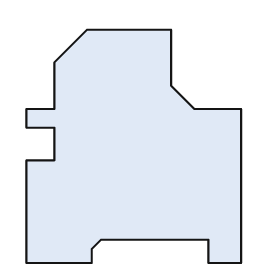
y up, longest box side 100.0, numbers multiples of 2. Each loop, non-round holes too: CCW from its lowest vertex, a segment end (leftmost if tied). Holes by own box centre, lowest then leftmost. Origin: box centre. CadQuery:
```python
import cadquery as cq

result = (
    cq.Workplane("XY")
    .moveTo(-46.0, -50.0)
    .lineTo(-18.0, -50.0)
    .lineTo(-18.0, -44.0)
    .lineTo(-14.0, -40.0)
    .lineTo(32.0, -40.0)
    .lineTo(32.0, -50.0)
    .lineTo(46.0, -50.0)
    .lineTo(46.0, 16.0)
    .lineTo(26.0, 16.0)
    .lineTo(16.0, 26.0)
    .lineTo(16.0, 50.0)
    .lineTo(-20.0, 50.0)
    .lineTo(-34.0, 36.0)
    .lineTo(-34.0, 16.0)
    .lineTo(-46.0, 16.0)
    .lineTo(-46.0, 8.0)
    .lineTo(-34.0, 8.0)
    .lineTo(-34.0, -6.0)
    .lineTo(-46.0, -6.0)
    .close()
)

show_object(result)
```